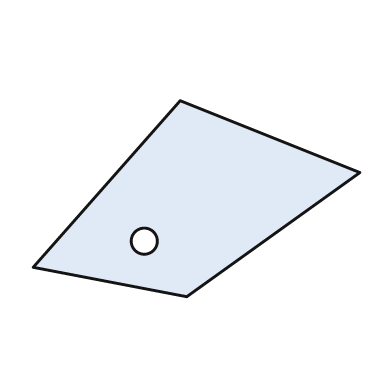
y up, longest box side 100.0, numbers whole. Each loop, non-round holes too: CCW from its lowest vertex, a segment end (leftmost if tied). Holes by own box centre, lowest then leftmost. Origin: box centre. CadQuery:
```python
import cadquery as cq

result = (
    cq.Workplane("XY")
    .moveTo(-3.0, -30.0)
    .lineTo(50.0, 8.0)
    .lineTo(-5.0, 30.0)
    .lineTo(-50.0, -21.0)
    .close()
    .moveTo(-16.0, -13.0)
    .circle(4.0)
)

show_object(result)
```